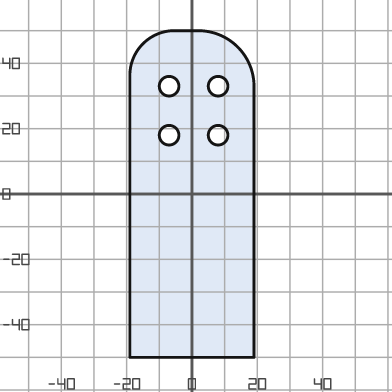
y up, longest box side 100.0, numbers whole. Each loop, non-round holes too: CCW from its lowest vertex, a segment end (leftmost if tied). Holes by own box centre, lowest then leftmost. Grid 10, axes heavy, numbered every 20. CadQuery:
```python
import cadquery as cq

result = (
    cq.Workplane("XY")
    .moveTo(-19.0, -50.0)
    .lineTo(19.0, -50.0)
    .lineTo(19.0, 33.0)
    .threePointArc((14.0, 45.0), (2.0, 50.0))
    .lineTo(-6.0, 50.0)
    .threePointArc((-15.0, 46.0), (-19.0, 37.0))
    .close()
    .moveTo(-7.0, 18.0)
    .circle(3.0)
    .moveTo(8.0, 18.0)
    .circle(3.0)
    .moveTo(-7.0, 33.0)
    .circle(3.0)
    .moveTo(8.0, 33.0)
    .circle(3.0)
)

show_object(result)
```